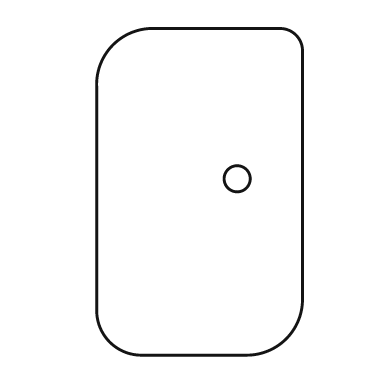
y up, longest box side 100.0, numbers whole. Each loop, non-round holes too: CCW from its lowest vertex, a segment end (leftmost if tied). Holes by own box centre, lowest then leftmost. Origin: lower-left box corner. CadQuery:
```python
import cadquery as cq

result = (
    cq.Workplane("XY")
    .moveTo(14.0, 0.0)
    .lineTo(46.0, 0.0)
    .threePointArc((58.0, 5.0), (63.0, 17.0))
    .lineTo(63.0, 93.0)
    .threePointArc((61.0, 98.0), (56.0, 100.0))
    .lineTo(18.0, 100.0)
    .threePointArc((5.0, 95.0), (0.0, 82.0))
    .lineTo(0.0, 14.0)
    .threePointArc((4.0, 4.0), (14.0, 0.0))
    .close()
    .moveTo(43.0, 54.0)
    .circle(4.0)
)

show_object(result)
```